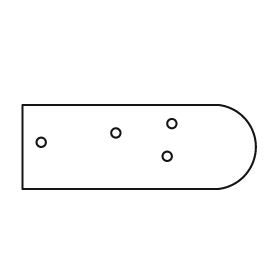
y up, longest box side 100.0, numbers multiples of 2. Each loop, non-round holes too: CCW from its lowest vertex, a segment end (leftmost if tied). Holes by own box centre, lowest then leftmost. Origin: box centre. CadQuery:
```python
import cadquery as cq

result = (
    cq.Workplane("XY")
    .moveTo(-50.0, -18.0)
    .lineTo(34.0, -18.0)
    .threePointArc((50.0, 0.0), (34.0, 18.0))
    .lineTo(-50.0, 18.0)
    .close()
    .moveTo(12.0, -4.0)
    .circle(2.0)
    .moveTo(-42.0, 2.0)
    .circle(2.0)
    .moveTo(-10.0, 6.0)
    .circle(2.0)
    .moveTo(14.0, 10.0)
    .circle(2.0)
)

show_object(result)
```